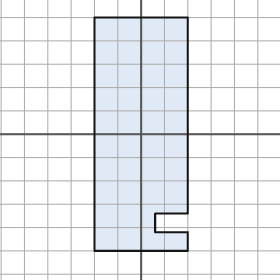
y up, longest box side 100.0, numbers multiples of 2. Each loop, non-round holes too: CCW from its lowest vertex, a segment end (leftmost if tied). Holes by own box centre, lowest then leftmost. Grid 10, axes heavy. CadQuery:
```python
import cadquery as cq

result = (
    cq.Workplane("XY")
    .moveTo(-20.0, -50.0)
    .lineTo(20.0, -50.0)
    .lineTo(20.0, -42.0)
    .lineTo(6.0, -42.0)
    .lineTo(6.0, -34.0)
    .lineTo(20.0, -34.0)
    .lineTo(20.0, 50.0)
    .lineTo(-20.0, 50.0)
    .close()
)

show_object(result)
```